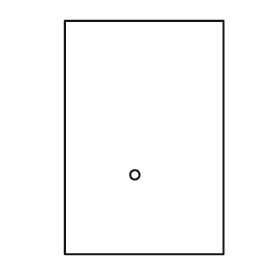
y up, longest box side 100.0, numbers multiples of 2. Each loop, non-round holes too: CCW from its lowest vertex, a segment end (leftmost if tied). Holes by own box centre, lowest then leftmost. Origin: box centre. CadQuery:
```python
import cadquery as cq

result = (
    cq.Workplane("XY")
    .moveTo(-34.0, -50.0)
    .lineTo(34.0, -50.0)
    .lineTo(34.0, 50.0)
    .lineTo(-34.0, 50.0)
    .close()
    .moveTo(-4.0, -16.0)
    .circle(2.0)
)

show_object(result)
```